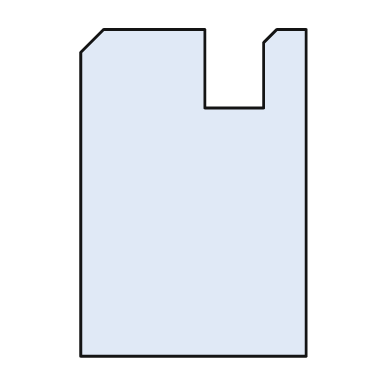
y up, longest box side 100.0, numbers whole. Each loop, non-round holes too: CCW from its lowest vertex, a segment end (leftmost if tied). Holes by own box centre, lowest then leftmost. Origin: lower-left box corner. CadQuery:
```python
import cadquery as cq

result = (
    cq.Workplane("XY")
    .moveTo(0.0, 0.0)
    .lineTo(69.0, 0.0)
    .lineTo(69.0, 100.0)
    .lineTo(60.0, 100.0)
    .lineTo(56.0, 96.0)
    .lineTo(56.0, 76.0)
    .lineTo(38.0, 76.0)
    .lineTo(38.0, 100.0)
    .lineTo(7.0, 100.0)
    .lineTo(0.0, 93.0)
    .close()
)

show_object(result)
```